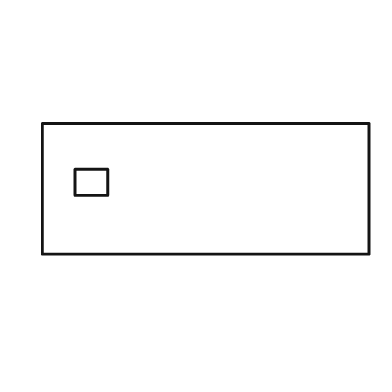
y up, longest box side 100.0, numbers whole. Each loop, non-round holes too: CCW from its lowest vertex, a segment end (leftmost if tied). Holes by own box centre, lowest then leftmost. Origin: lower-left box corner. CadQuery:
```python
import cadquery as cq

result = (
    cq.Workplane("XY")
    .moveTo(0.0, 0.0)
    .lineTo(100.0, 0.0)
    .lineTo(100.0, 40.0)
    .lineTo(0.0, 40.0)
    .close()
    .moveTo(10.0, 18.0)
    .lineTo(20.0, 18.0)
    .lineTo(20.0, 26.0)
    .lineTo(10.0, 26.0)
    .close()
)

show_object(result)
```